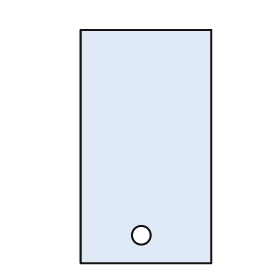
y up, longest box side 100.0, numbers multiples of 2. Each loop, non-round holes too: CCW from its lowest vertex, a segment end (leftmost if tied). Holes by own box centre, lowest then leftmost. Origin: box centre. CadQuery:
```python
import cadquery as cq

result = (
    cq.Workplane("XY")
    .moveTo(-28.0, -50.0)
    .lineTo(28.0, -50.0)
    .lineTo(28.0, 50.0)
    .lineTo(-28.0, 50.0)
    .close()
    .moveTo(-2.0, -38.0)
    .circle(4.0)
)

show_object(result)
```